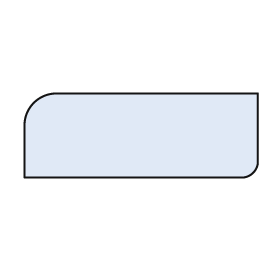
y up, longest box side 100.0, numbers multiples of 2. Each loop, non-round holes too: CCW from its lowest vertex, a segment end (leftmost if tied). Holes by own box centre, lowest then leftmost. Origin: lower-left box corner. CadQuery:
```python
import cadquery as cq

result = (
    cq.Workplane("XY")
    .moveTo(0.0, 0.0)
    .lineTo(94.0, 0.0)
    .threePointArc((98.0, 2.0), (100.0, 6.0))
    .lineTo(100.0, 36.0)
    .lineTo(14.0, 36.0)
    .threePointArc((4.0, 32.0), (0.0, 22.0))
    .close()
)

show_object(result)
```